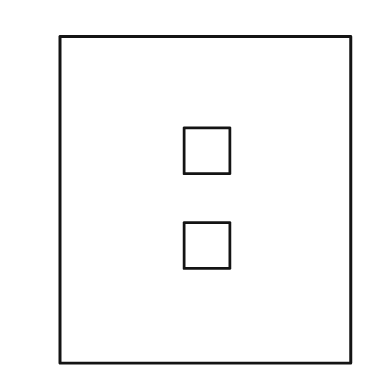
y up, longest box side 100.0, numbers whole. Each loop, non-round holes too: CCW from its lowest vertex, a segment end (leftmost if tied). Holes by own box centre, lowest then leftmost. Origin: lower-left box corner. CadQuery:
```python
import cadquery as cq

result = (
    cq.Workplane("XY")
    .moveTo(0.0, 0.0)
    .lineTo(89.0, 0.0)
    .lineTo(89.0, 100.0)
    .lineTo(0.0, 100.0)
    .close()
    .moveTo(38.0, 29.0)
    .lineTo(52.0, 29.0)
    .lineTo(52.0, 43.0)
    .lineTo(38.0, 43.0)
    .close()
    .moveTo(38.0, 58.0)
    .lineTo(52.0, 58.0)
    .lineTo(52.0, 72.0)
    .lineTo(38.0, 72.0)
    .close()
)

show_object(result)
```